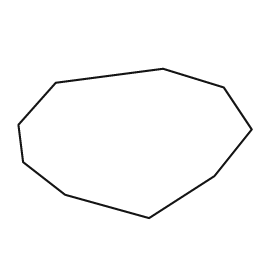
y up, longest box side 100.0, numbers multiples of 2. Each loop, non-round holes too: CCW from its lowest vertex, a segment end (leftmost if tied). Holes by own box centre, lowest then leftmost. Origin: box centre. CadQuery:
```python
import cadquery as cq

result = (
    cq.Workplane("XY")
    .moveTo(6.0, -32.0)
    .lineTo(34.0, -14.0)
    .lineTo(50.0, 6.0)
    .lineTo(38.0, 24.0)
    .lineTo(12.0, 32.0)
    .lineTo(-34.0, 26.0)
    .lineTo(-50.0, 8.0)
    .lineTo(-48.0, -8.0)
    .lineTo(-30.0, -22.0)
    .close()
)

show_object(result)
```